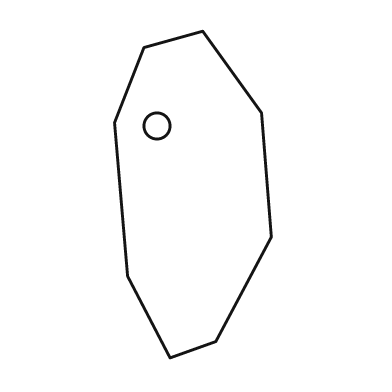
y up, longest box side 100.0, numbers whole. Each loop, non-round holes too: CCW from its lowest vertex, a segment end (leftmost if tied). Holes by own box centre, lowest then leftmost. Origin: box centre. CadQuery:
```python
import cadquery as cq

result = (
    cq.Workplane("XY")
    .moveTo(-7.0, -50.0)
    .lineTo(7.0, -45.0)
    .lineTo(24.0, -13.0)
    .lineTo(21.0, 25.0)
    .lineTo(3.0, 50.0)
    .lineTo(-15.0, 45.0)
    .lineTo(-24.0, 22.0)
    .lineTo(-20.0, -25.0)
    .close()
    .moveTo(-11.0, 21.0)
    .circle(4.0)
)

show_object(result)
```